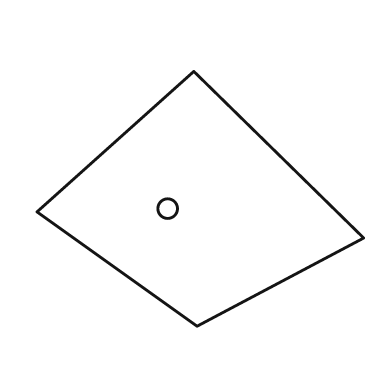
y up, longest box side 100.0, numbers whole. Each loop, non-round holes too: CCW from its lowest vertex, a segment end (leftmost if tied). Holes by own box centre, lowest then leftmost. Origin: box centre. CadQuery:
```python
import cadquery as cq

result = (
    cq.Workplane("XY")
    .moveTo(-1.0, -39.0)
    .lineTo(50.0, -12.0)
    .lineTo(-2.0, 39.0)
    .lineTo(-50.0, -4.0)
    .close()
    .moveTo(-10.0, -3.0)
    .circle(3.0)
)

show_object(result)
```